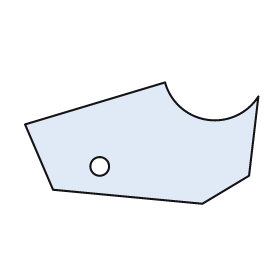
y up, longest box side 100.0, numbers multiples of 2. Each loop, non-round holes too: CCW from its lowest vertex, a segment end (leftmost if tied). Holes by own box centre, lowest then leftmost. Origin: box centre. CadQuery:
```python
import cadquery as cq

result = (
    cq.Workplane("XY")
    .moveTo(26.0, -26.0)
    .lineTo(46.0, -14.0)
    .lineTo(50.0, 20.0)
    .threePointArc((28.0, 10.0), (10.0, 26.0))
    .lineTo(-50.0, 8.0)
    .lineTo(-38.0, -20.0)
    .close()
    .moveTo(-18.0, -10.0)
    .circle(4.0)
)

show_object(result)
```